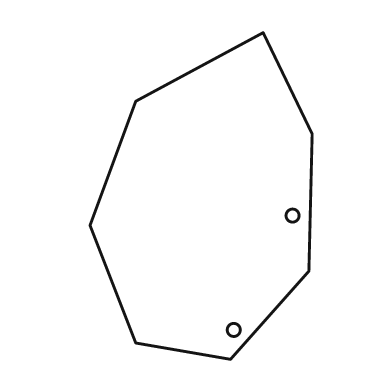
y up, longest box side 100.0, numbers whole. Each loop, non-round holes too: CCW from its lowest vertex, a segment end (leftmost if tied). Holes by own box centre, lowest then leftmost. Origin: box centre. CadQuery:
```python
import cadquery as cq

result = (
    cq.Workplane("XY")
    .moveTo(9.0, -50.0)
    .lineTo(33.0, -23.0)
    .lineTo(34.0, 19.0)
    .lineTo(19.0, 50.0)
    .lineTo(-20.0, 29.0)
    .lineTo(-34.0, -9.0)
    .lineTo(-20.0, -45.0)
    .close()
    .moveTo(10.0, -41.0)
    .circle(2.0)
    .moveTo(28.0, -6.0)
    .circle(2.0)
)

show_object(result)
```